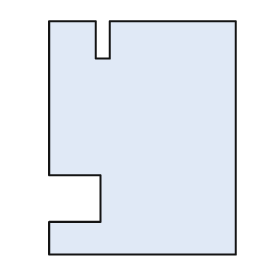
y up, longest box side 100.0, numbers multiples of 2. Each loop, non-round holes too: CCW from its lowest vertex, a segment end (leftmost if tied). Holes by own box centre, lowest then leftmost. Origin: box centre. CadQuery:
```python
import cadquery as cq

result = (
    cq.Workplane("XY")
    .moveTo(-40.0, -50.0)
    .lineTo(40.0, -50.0)
    .lineTo(40.0, 50.0)
    .lineTo(-14.0, 50.0)
    .lineTo(-14.0, 34.0)
    .lineTo(-20.0, 34.0)
    .lineTo(-20.0, 50.0)
    .lineTo(-40.0, 50.0)
    .lineTo(-40.0, -16.0)
    .lineTo(-18.0, -16.0)
    .lineTo(-18.0, -36.0)
    .lineTo(-40.0, -36.0)
    .close()
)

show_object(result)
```